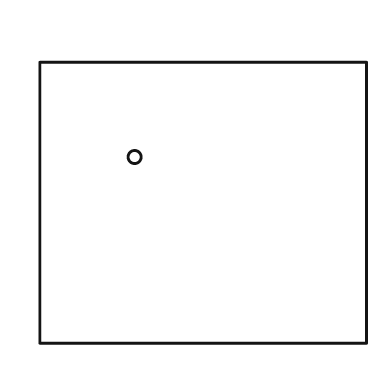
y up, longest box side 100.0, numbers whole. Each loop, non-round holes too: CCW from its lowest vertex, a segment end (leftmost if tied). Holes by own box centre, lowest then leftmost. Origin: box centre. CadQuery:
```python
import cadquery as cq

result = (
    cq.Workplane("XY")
    .moveTo(-50.0, -43.0)
    .lineTo(50.0, -43.0)
    .lineTo(50.0, 43.0)
    .lineTo(-50.0, 43.0)
    .close()
    .moveTo(-21.0, 14.0)
    .circle(2.0)
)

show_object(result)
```